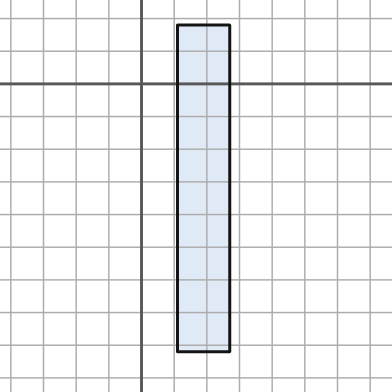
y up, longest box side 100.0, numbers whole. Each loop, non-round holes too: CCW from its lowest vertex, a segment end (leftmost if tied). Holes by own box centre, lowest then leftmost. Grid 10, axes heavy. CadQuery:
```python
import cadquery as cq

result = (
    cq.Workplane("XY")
    .moveTo(11.0, -82.0)
    .lineTo(27.0, -82.0)
    .lineTo(27.0, 18.0)
    .lineTo(11.0, 18.0)
    .close()
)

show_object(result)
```